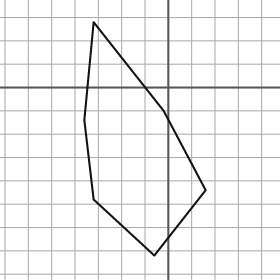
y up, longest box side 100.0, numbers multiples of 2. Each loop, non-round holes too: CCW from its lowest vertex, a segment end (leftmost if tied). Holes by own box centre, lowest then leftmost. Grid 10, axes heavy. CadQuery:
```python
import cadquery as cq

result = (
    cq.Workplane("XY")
    .moveTo(-6.0, -72.0)
    .lineTo(16.0, -44.0)
    .lineTo(-2.0, -10.0)
    .lineTo(-32.0, 28.0)
    .lineTo(-36.0, -14.0)
    .lineTo(-32.0, -48.0)
    .close()
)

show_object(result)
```